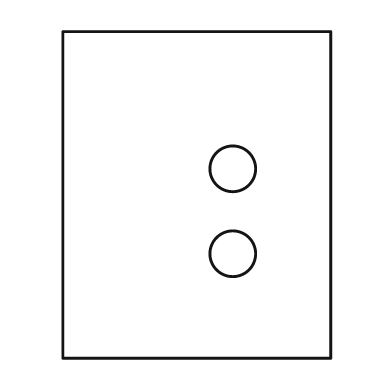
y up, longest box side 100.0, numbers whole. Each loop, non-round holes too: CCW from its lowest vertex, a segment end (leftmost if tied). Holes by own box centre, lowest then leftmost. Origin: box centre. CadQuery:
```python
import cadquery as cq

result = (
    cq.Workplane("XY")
    .moveTo(-41.0, -50.0)
    .lineTo(41.0, -50.0)
    .lineTo(41.0, 50.0)
    .lineTo(-41.0, 50.0)
    .close()
    .moveTo(11.0, -18.0)
    .circle(7.0)
    .moveTo(11.0, 8.0)
    .circle(7.0)
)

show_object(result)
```